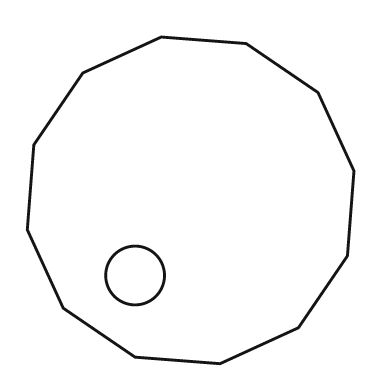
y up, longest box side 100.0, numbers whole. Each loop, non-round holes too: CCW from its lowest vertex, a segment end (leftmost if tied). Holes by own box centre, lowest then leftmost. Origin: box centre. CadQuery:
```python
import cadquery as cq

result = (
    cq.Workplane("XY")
    .moveTo(9.0, -50.0)
    .lineTo(33.0, -39.0)
    .lineTo(48.0, -17.0)
    .lineTo(50.0, 9.0)
    .lineTo(39.0, 33.0)
    .lineTo(17.0, 48.0)
    .lineTo(-9.0, 50.0)
    .lineTo(-33.0, 39.0)
    .lineTo(-48.0, 17.0)
    .lineTo(-50.0, -9.0)
    .lineTo(-39.0, -33.0)
    .lineTo(-17.0, -48.0)
    .close()
    .moveTo(-17.0, -23.0)
    .circle(9.0)
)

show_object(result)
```